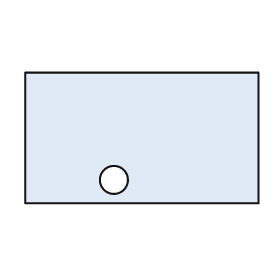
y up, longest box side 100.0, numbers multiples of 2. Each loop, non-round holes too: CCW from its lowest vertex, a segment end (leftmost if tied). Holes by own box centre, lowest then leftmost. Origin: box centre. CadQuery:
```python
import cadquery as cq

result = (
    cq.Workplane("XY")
    .moveTo(-50.0, -28.0)
    .lineTo(50.0, -28.0)
    .lineTo(50.0, 28.0)
    .lineTo(-50.0, 28.0)
    .close()
    .moveTo(-12.0, -18.0)
    .circle(6.0)
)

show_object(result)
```